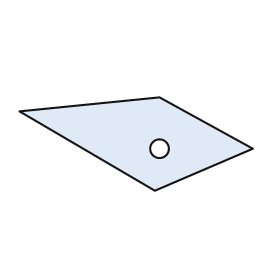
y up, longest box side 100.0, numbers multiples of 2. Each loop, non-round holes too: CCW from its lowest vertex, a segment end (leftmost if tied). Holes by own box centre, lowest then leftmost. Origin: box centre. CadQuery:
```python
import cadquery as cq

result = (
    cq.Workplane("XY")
    .moveTo(8.0, -20.0)
    .lineTo(50.0, -2.0)
    .lineTo(10.0, 20.0)
    .lineTo(-50.0, 14.0)
    .close()
    .moveTo(10.0, -2.0)
    .circle(4.0)
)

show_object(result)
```